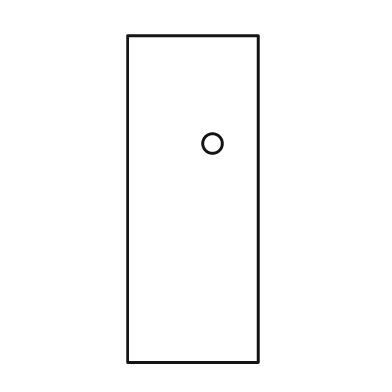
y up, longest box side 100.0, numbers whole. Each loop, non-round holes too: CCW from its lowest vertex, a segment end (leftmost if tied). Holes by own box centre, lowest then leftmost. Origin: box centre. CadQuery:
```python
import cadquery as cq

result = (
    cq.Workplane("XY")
    .moveTo(-20.0, -50.0)
    .lineTo(20.0, -50.0)
    .lineTo(20.0, 50.0)
    .lineTo(-20.0, 50.0)
    .close()
    .moveTo(6.0, 17.0)
    .circle(3.0)
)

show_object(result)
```